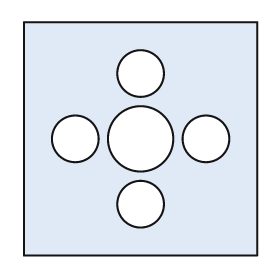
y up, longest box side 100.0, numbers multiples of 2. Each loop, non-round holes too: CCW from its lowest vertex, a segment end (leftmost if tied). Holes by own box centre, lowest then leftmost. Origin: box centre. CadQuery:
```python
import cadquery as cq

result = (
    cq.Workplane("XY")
    .moveTo(-50.0, -50.0)
    .lineTo(50.0, -50.0)
    .lineTo(50.0, 50.0)
    .lineTo(-50.0, 50.0)
    .close()
    .moveTo(0.0, -28.0)
    .circle(10.0)
    .moveTo(-28.0, 0.0)
    .circle(10.0)
    .moveTo(0.0, 0.0)
    .circle(14.0)
    .moveTo(28.0, 0.0)
    .circle(10.0)
    .moveTo(0.0, 28.0)
    .circle(10.0)
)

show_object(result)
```